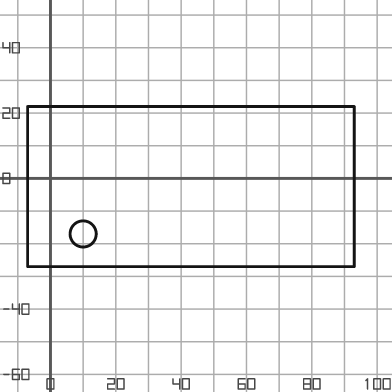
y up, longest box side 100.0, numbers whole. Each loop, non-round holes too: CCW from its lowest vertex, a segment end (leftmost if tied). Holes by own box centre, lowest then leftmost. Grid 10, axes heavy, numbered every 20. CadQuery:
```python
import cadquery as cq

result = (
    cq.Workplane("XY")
    .moveTo(-7.0, -27.0)
    .lineTo(93.0, -27.0)
    .lineTo(93.0, 22.0)
    .lineTo(-7.0, 22.0)
    .close()
    .moveTo(10.0, -17.0)
    .circle(4.0)
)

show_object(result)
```